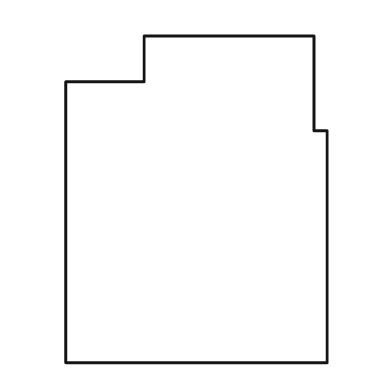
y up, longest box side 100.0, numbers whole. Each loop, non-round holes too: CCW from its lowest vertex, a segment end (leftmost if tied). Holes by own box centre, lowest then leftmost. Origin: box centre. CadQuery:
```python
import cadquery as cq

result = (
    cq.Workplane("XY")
    .moveTo(-40.0, -50.0)
    .lineTo(40.0, -50.0)
    .lineTo(40.0, 21.0)
    .lineTo(36.0, 21.0)
    .lineTo(36.0, 50.0)
    .lineTo(-16.0, 50.0)
    .lineTo(-16.0, 36.0)
    .lineTo(-40.0, 36.0)
    .close()
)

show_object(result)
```